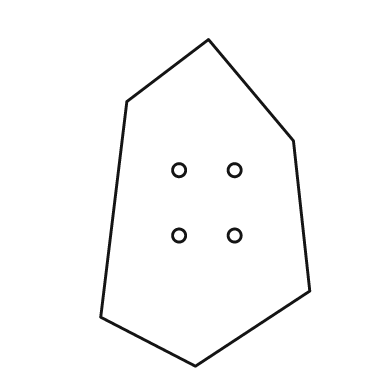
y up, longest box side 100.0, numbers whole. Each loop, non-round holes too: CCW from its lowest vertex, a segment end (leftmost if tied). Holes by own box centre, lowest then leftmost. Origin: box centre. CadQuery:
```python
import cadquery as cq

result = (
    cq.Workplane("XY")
    .moveTo(-3.0, -50.0)
    .lineTo(32.0, -27.0)
    .lineTo(27.0, 19.0)
    .lineTo(1.0, 50.0)
    .lineTo(-24.0, 31.0)
    .lineTo(-32.0, -35.0)
    .close()
    .moveTo(-8.0, -10.0)
    .circle(2.0)
    .moveTo(9.0, -10.0)
    .circle(2.0)
    .moveTo(-8.0, 10.0)
    .circle(2.0)
    .moveTo(9.0, 10.0)
    .circle(2.0)
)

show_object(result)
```